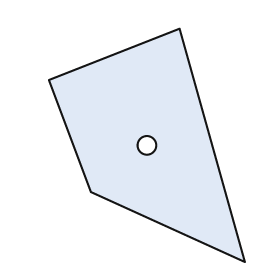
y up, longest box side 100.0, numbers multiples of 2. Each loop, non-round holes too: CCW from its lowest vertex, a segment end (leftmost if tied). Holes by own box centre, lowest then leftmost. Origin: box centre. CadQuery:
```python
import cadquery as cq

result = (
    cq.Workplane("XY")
    .moveTo(42.0, -50.0)
    .lineTo(14.0, 50.0)
    .lineTo(-42.0, 28.0)
    .lineTo(-24.0, -20.0)
    .close()
    .moveTo(0.0, 0.0)
    .circle(4.0)
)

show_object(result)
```